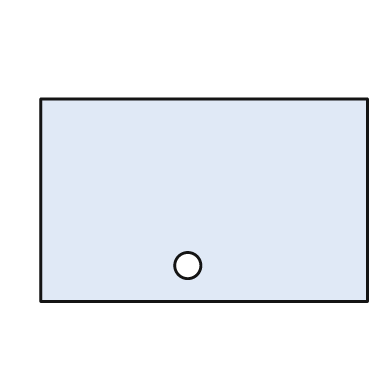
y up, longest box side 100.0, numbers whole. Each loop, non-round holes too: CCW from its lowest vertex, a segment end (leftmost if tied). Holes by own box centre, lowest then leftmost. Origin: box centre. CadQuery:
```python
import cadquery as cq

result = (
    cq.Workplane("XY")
    .moveTo(-50.0, -31.0)
    .lineTo(50.0, -31.0)
    .lineTo(50.0, 31.0)
    .lineTo(-50.0, 31.0)
    .close()
    .moveTo(-5.0, -20.0)
    .circle(4.0)
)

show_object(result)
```